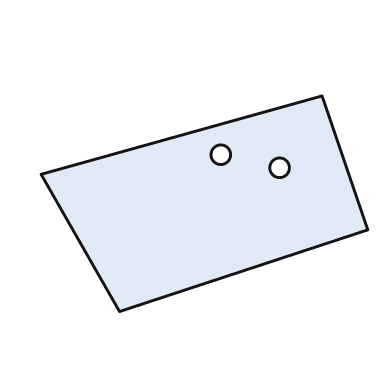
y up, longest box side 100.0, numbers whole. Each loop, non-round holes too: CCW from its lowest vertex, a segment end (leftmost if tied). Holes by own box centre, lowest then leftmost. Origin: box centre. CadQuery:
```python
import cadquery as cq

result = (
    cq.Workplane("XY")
    .moveTo(-26.0, -33.0)
    .lineTo(50.0, -8.0)
    .lineTo(36.0, 33.0)
    .lineTo(-50.0, 9.0)
    .close()
    .moveTo(23.0, 11.0)
    .circle(3.0)
    .moveTo(5.0, 15.0)
    .circle(3.0)
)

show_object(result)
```